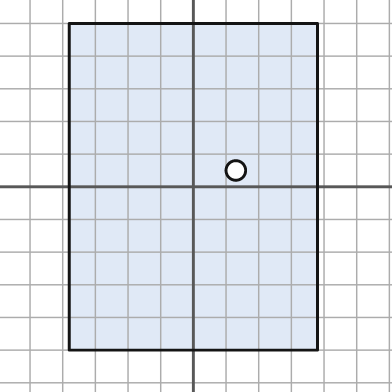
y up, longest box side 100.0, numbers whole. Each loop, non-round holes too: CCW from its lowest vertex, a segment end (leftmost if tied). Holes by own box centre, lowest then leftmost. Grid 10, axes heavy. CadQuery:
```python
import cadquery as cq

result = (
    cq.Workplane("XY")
    .moveTo(-38.0, -50.0)
    .lineTo(38.0, -50.0)
    .lineTo(38.0, 50.0)
    .lineTo(-38.0, 50.0)
    .close()
    .moveTo(13.0, 5.0)
    .circle(3.0)
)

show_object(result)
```